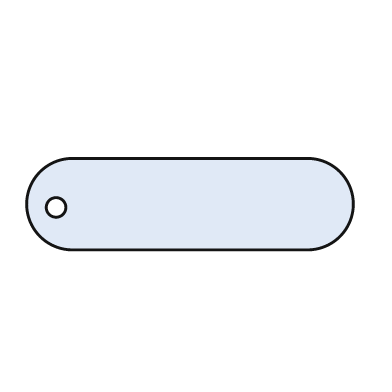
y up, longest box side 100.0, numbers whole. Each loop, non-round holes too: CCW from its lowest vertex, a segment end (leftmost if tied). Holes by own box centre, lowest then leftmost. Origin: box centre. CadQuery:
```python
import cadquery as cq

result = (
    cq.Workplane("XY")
    .moveTo(-36.0, -14.0)
    .lineTo(36.0, -14.0)
    .threePointArc((50.0, 0.0), (36.0, 14.0))
    .lineTo(-36.0, 14.0)
    .threePointArc((-50.0, 0.0), (-36.0, -14.0))
    .close()
    .moveTo(-41.0, -1.0)
    .circle(3.0)
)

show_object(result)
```